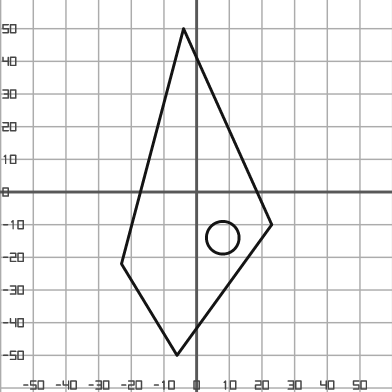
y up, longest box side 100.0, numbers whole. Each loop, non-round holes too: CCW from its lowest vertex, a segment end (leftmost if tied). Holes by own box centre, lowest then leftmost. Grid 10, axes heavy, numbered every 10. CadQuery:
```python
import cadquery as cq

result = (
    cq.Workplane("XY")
    .moveTo(-6.0, -50.0)
    .lineTo(23.0, -10.0)
    .lineTo(-4.0, 50.0)
    .lineTo(-23.0, -22.0)
    .close()
    .moveTo(8.0, -14.0)
    .circle(5.0)
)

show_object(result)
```